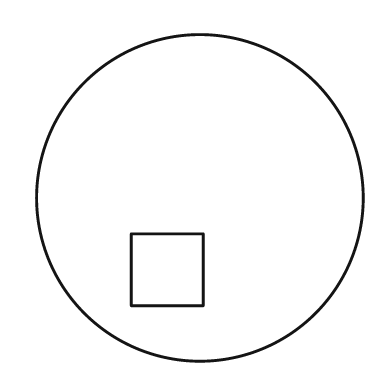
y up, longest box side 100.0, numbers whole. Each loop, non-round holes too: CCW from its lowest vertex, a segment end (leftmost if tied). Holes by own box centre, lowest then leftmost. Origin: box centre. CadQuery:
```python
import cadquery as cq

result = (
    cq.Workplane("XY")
    .moveTo(0.0, 0.0)
    .circle(50.0)
    .moveTo(-21.0, -33.0)
    .lineTo(1.0, -33.0)
    .lineTo(1.0, -11.0)
    .lineTo(-21.0, -11.0)
    .close()
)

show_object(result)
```